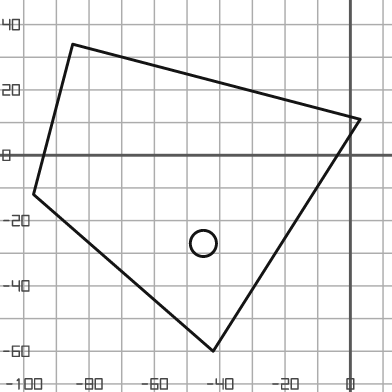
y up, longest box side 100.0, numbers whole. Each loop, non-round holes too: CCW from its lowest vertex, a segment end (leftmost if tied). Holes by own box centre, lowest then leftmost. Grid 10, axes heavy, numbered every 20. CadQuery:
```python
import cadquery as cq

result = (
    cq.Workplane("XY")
    .moveTo(-42.0, -60.0)
    .lineTo(3.0, 11.0)
    .lineTo(-85.0, 34.0)
    .lineTo(-97.0, -12.0)
    .close()
    .moveTo(-45.0, -27.0)
    .circle(4.0)
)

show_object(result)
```